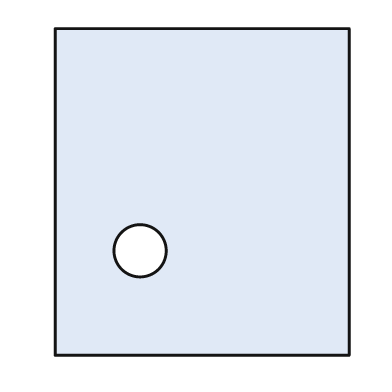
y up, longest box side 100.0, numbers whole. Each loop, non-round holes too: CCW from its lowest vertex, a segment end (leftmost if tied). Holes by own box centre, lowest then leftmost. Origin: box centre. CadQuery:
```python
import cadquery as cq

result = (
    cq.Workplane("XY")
    .moveTo(-45.0, -50.0)
    .lineTo(45.0, -50.0)
    .lineTo(45.0, 50.0)
    .lineTo(-45.0, 50.0)
    .close()
    .moveTo(-19.0, -18.0)
    .circle(8.0)
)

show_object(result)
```